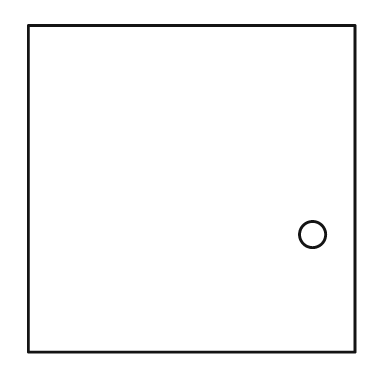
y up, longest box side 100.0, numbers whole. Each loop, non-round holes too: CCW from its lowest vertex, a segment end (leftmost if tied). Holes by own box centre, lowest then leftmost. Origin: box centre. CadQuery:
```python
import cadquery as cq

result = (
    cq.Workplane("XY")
    .moveTo(-50.0, -50.0)
    .lineTo(50.0, -50.0)
    .lineTo(50.0, 50.0)
    .lineTo(-50.0, 50.0)
    .close()
    .moveTo(37.0, -14.0)
    .circle(4.0)
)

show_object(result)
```